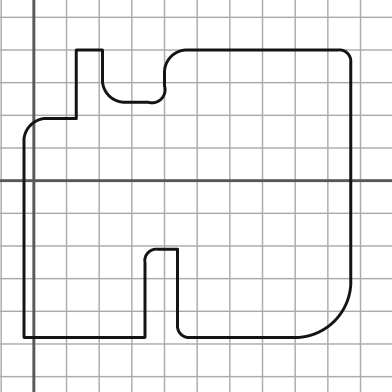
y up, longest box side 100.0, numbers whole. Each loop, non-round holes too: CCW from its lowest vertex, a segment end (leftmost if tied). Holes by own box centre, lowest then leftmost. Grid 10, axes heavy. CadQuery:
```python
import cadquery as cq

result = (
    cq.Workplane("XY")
    .moveTo(-3.0, -48.0)
    .lineTo(34.0, -48.0)
    .lineTo(34.0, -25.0)
    .threePointArc((35.0, -22.0), (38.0, -21.0))
    .lineTo(44.0, -21.0)
    .lineTo(44.0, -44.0)
    .threePointArc((45.0, -47.0), (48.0, -48.0))
    .lineTo(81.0, -48.0)
    .threePointArc((92.0, -43.0), (97.0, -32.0))
    .lineTo(97.0, 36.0)
    .threePointArc((96.0, 39.0), (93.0, 40.0))
    .lineTo(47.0, 40.0)
    .threePointArc((42.0, 38.0), (40.0, 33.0))
    .lineTo(40.0, 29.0)
    .threePointArc((39.0, 25.0), (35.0, 24.0))
    .lineTo(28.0, 24.0)
    .threePointArc((23.0, 26.0), (21.0, 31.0))
    .lineTo(21.0, 40.0)
    .lineTo(13.0, 40.0)
    .lineTo(13.0, 19.0)
    .lineTo(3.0, 19.0)
    .threePointArc((-1.0, 17.0), (-3.0, 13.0))
    .close()
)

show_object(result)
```